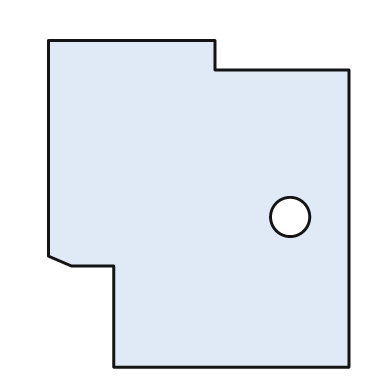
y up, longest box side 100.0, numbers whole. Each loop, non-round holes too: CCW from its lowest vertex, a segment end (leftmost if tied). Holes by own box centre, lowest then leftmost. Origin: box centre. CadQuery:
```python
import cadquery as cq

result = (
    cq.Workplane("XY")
    .moveTo(-26.0, -50.0)
    .lineTo(46.0, -50.0)
    .lineTo(46.0, 41.0)
    .lineTo(5.0, 41.0)
    .lineTo(5.0, 50.0)
    .lineTo(-46.0, 50.0)
    .lineTo(-46.0, -16.0)
    .lineTo(-39.0, -19.0)
    .lineTo(-26.0, -19.0)
    .close()
    .moveTo(28.0, -4.0)
    .circle(6.0)
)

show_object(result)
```